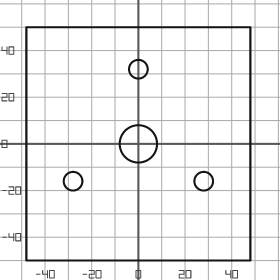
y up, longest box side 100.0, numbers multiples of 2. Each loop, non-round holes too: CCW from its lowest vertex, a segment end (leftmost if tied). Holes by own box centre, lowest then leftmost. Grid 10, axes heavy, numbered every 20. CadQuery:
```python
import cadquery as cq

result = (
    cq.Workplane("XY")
    .moveTo(-48.0, -50.0)
    .lineTo(48.0, -50.0)
    .lineTo(48.0, 50.0)
    .lineTo(-48.0, 50.0)
    .close()
    .moveTo(-28.0, -16.0)
    .circle(4.0)
    .moveTo(28.0, -16.0)
    .circle(4.0)
    .moveTo(0.0, 0.0)
    .circle(8.0)
    .moveTo(0.0, 32.0)
    .circle(4.0)
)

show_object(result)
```